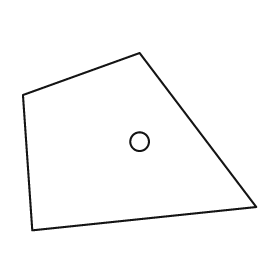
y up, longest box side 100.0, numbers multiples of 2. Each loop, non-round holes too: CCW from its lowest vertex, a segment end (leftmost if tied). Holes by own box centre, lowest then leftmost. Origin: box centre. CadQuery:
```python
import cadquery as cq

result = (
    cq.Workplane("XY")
    .moveTo(-46.0, -38.0)
    .lineTo(50.0, -28.0)
    .lineTo(0.0, 38.0)
    .lineTo(-50.0, 20.0)
    .close()
    .moveTo(0.0, 0.0)
    .circle(4.0)
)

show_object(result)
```